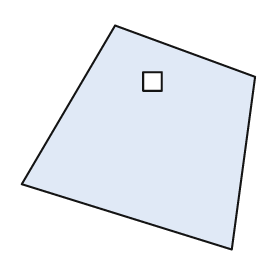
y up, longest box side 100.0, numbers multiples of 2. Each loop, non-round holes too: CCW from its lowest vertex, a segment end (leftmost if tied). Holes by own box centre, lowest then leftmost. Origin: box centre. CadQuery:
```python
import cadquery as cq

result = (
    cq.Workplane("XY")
    .moveTo(40.0, -48.0)
    .lineTo(50.0, 26.0)
    .lineTo(-10.0, 48.0)
    .lineTo(-50.0, -20.0)
    .close()
    .moveTo(2.0, 20.0)
    .lineTo(10.0, 20.0)
    .lineTo(10.0, 28.0)
    .lineTo(2.0, 28.0)
    .close()
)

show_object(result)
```